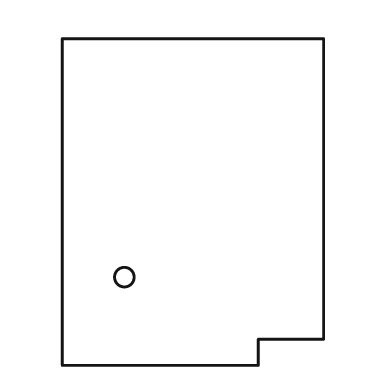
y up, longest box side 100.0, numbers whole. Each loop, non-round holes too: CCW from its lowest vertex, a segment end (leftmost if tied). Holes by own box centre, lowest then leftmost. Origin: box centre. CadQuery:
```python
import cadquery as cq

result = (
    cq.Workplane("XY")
    .moveTo(-40.0, -50.0)
    .lineTo(20.0, -50.0)
    .lineTo(20.0, -42.0)
    .lineTo(40.0, -42.0)
    .lineTo(40.0, 50.0)
    .lineTo(-40.0, 50.0)
    .close()
    .moveTo(-21.0, -23.0)
    .circle(3.0)
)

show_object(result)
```